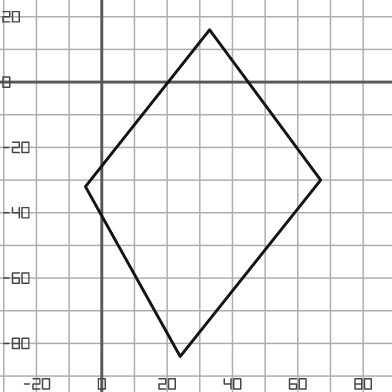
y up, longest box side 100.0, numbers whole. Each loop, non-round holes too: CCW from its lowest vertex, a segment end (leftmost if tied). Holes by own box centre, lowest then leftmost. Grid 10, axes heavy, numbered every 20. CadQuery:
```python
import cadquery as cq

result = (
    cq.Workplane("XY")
    .moveTo(24.0, -84.0)
    .lineTo(67.0, -30.0)
    .lineTo(33.0, 16.0)
    .lineTo(-5.0, -32.0)
    .close()
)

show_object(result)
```